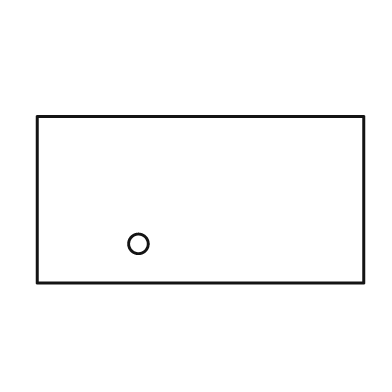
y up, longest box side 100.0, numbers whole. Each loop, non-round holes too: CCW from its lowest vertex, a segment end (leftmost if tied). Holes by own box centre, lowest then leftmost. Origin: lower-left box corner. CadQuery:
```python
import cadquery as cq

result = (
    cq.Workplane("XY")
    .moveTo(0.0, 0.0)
    .lineTo(100.0, 0.0)
    .lineTo(100.0, 51.0)
    .lineTo(0.0, 51.0)
    .close()
    .moveTo(31.0, 12.0)
    .circle(3.0)
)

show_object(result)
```